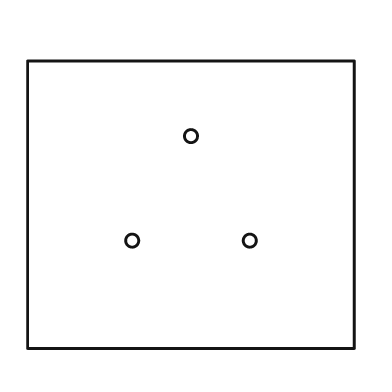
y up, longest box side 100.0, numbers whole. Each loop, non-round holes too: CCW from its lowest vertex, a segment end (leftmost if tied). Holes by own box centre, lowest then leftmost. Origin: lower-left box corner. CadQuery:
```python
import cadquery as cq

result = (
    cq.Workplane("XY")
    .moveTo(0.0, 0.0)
    .lineTo(100.0, 0.0)
    .lineTo(100.0, 88.0)
    .lineTo(0.0, 88.0)
    .close()
    .moveTo(32.0, 33.0)
    .circle(2.0)
    .moveTo(68.0, 33.0)
    .circle(2.0)
    .moveTo(50.0, 65.0)
    .circle(2.0)
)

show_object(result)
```